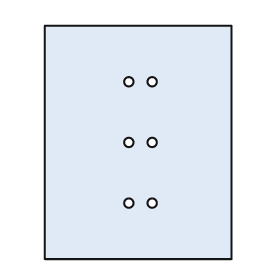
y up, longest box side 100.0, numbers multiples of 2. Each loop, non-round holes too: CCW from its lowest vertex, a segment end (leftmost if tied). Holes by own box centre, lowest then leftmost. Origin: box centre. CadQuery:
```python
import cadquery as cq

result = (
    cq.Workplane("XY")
    .moveTo(-40.0, -50.0)
    .lineTo(40.0, -50.0)
    .lineTo(40.0, 50.0)
    .lineTo(-40.0, 50.0)
    .close()
    .moveTo(-4.0, -26.0)
    .circle(2.0)
    .moveTo(6.0, -26.0)
    .circle(2.0)
    .moveTo(-4.0, 0.0)
    .circle(2.0)
    .moveTo(6.0, 0.0)
    .circle(2.0)
    .moveTo(-4.0, 26.0)
    .circle(2.0)
    .moveTo(6.0, 26.0)
    .circle(2.0)
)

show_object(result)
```